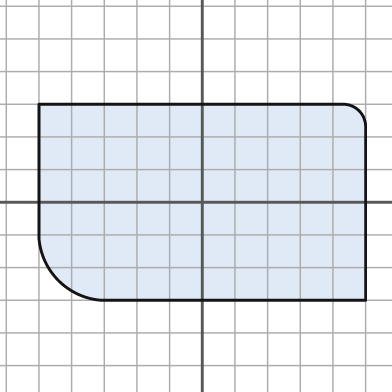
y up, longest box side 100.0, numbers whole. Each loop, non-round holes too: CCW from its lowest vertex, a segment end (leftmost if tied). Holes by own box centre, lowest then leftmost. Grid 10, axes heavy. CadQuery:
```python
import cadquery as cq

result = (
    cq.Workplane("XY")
    .moveTo(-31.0, -30.0)
    .lineTo(50.0, -30.0)
    .lineTo(50.0, 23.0)
    .threePointArc((48.0, 28.0), (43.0, 30.0))
    .lineTo(-50.0, 30.0)
    .lineTo(-50.0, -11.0)
    .threePointArc((-44.0, -24.0), (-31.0, -30.0))
    .close()
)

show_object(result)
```